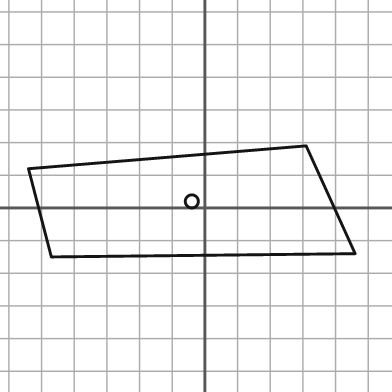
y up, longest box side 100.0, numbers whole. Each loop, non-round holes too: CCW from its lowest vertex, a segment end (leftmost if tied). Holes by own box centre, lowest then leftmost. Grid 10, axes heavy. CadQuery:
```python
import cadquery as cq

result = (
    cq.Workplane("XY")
    .moveTo(-47.0, -15.0)
    .lineTo(46.0, -14.0)
    .lineTo(31.0, 19.0)
    .lineTo(-54.0, 12.0)
    .close()
    .moveTo(-4.0, 2.0)
    .circle(2.0)
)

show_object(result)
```